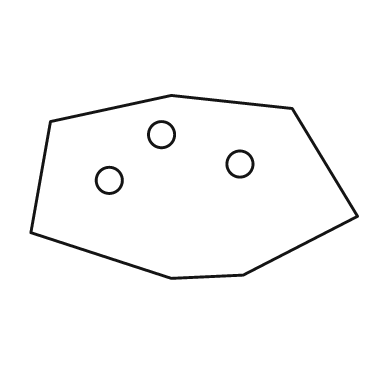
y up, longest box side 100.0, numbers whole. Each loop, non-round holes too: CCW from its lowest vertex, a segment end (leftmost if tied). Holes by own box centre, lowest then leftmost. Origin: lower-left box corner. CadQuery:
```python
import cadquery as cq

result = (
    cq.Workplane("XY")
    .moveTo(43.0, 0.0)
    .lineTo(65.0, 1.0)
    .lineTo(100.0, 19.0)
    .lineTo(80.0, 52.0)
    .lineTo(43.0, 56.0)
    .lineTo(6.0, 48.0)
    .lineTo(0.0, 14.0)
    .close()
    .moveTo(24.0, 30.0)
    .circle(4.0)
    .moveTo(64.0, 35.0)
    .circle(4.0)
    .moveTo(40.0, 44.0)
    .circle(4.0)
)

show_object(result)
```